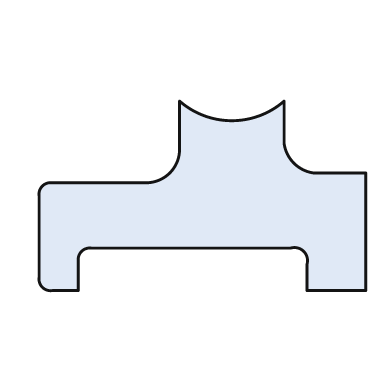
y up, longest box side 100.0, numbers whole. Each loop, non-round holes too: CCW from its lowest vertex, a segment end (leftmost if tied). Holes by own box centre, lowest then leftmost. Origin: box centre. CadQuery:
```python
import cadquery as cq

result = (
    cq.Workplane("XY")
    .moveTo(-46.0, -29.0)
    .lineTo(-38.0, -29.0)
    .lineTo(-38.0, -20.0)
    .threePointArc((-37.0, -17.0), (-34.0, -16.0))
    .lineTo(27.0, -16.0)
    .threePointArc((31.0, -17.0), (32.0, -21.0))
    .lineTo(32.0, -29.0)
    .lineTo(50.0, -29.0)
    .lineTo(50.0, 7.0)
    .lineTo(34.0, 7.0)
    .threePointArc((28.0, 10.0), (25.0, 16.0))
    .lineTo(25.0, 29.0)
    .threePointArc((9.0, 23.0), (-7.0, 29.0))
    .lineTo(-7.0, 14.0)
    .threePointArc((-10.0, 7.0), (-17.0, 4.0))
    .lineTo(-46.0, 4.0)
    .threePointArc((-49.0, 3.0), (-50.0, 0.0))
    .lineTo(-50.0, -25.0)
    .threePointArc((-49.0, -28.0), (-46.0, -29.0))
    .close()
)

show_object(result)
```